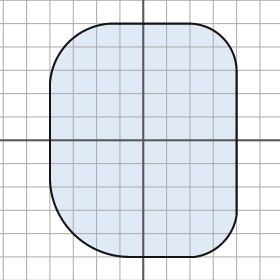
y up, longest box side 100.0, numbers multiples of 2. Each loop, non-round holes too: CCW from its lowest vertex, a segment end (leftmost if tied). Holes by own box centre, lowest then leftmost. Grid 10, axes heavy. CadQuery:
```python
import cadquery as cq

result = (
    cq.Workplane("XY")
    .moveTo(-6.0, -50.0)
    .lineTo(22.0, -50.0)
    .threePointArc((34.0, -44.0), (40.0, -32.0))
    .lineTo(40.0, 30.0)
    .threePointArc((34.0, 44.0), (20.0, 50.0))
    .lineTo(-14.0, 50.0)
    .threePointArc((-32.0, 42.0), (-40.0, 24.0))
    .lineTo(-40.0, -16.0)
    .threePointArc((-30.0, -40.0), (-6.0, -50.0))
    .close()
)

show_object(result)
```